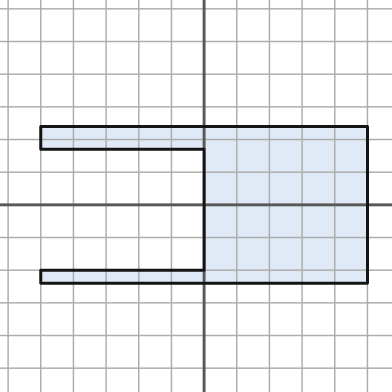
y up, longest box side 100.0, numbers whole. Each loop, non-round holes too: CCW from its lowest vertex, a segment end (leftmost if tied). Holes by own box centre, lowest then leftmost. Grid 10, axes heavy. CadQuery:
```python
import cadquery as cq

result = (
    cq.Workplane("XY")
    .moveTo(-50.0, -24.0)
    .lineTo(50.0, -24.0)
    .lineTo(50.0, 24.0)
    .lineTo(-50.0, 24.0)
    .lineTo(-50.0, 17.0)
    .lineTo(0.0, 17.0)
    .lineTo(0.0, -20.0)
    .lineTo(-50.0, -20.0)
    .close()
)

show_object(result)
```